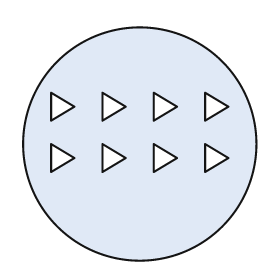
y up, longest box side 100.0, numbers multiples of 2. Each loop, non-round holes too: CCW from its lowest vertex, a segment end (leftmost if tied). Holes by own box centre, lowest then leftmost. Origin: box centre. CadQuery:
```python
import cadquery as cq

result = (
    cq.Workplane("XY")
    .moveTo(0.0, 0.0)
    .circle(50.0)
    .moveTo(-38.0, -12.0)
    .lineTo(-28.0, -6.0)
    .lineTo(-38.0, 0.0)
    .close()
    .moveTo(-16.0, -12.0)
    .lineTo(-6.0, -6.0)
    .lineTo(-16.0, 0.0)
    .close()
    .moveTo(6.0, -12.0)
    .lineTo(16.0, -6.0)
    .lineTo(6.0, 0.0)
    .close()
    .moveTo(28.0, -12.0)
    .lineTo(38.0, -6.0)
    .lineTo(28.0, 0.0)
    .close()
    .moveTo(-38.0, 10.0)
    .lineTo(-28.0, 16.0)
    .lineTo(-38.0, 22.0)
    .close()
    .moveTo(-16.0, 10.0)
    .lineTo(-6.0, 16.0)
    .lineTo(-16.0, 22.0)
    .close()
    .moveTo(6.0, 10.0)
    .lineTo(16.0, 16.0)
    .lineTo(6.0, 22.0)
    .close()
    .moveTo(28.0, 10.0)
    .lineTo(38.0, 16.0)
    .lineTo(28.0, 22.0)
    .close()
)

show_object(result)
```